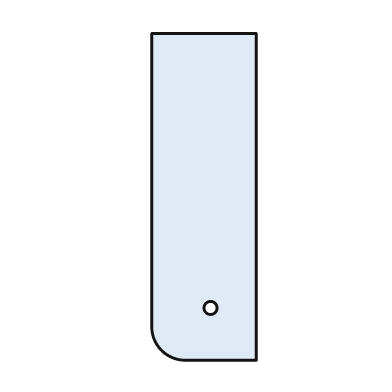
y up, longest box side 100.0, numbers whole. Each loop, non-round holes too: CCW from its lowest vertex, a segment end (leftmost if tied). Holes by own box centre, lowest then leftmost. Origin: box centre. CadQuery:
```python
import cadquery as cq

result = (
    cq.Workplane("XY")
    .moveTo(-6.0, -50.0)
    .lineTo(16.0, -50.0)
    .lineTo(16.0, 50.0)
    .lineTo(-16.0, 50.0)
    .lineTo(-16.0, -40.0)
    .threePointArc((-13.0, -47.0), (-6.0, -50.0))
    .close()
    .moveTo(2.0, -34.0)
    .circle(2.0)
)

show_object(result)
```